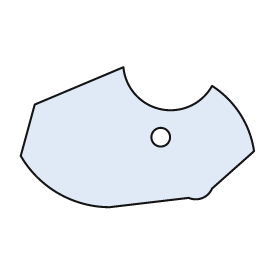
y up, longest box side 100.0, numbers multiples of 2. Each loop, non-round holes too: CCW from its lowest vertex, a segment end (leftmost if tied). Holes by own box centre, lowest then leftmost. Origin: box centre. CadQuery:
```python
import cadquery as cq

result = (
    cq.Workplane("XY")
    .moveTo(-12.0, -30.0)
    .lineTo(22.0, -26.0)
    .threePointArc((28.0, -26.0), (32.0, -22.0))
    .lineTo(50.0, -6.0)
    .threePointArc((44.0, 10.0), (32.0, 22.0))
    .threePointArc((10.0, 12.0), (-6.0, 30.0))
    .lineTo(-44.0, 14.0)
    .lineTo(-50.0, -8.0)
    .threePointArc((-34.0, -24.0), (-12.0, -30.0))
    .close()
    .moveTo(10.0, 0.0)
    .circle(4.0)
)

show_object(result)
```